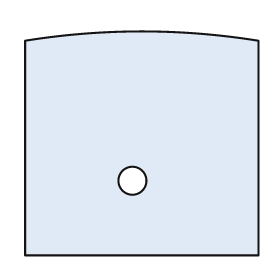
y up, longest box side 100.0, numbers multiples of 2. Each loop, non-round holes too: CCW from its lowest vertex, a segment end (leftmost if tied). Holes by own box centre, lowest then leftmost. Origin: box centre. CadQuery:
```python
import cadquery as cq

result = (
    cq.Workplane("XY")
    .moveTo(-50.0, -48.0)
    .lineTo(50.0, -48.0)
    .lineTo(50.0, 44.0)
    .threePointArc((0.0, 48.0), (-50.0, 44.0))
    .close()
    .moveTo(-4.0, -16.0)
    .circle(6.0)
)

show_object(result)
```